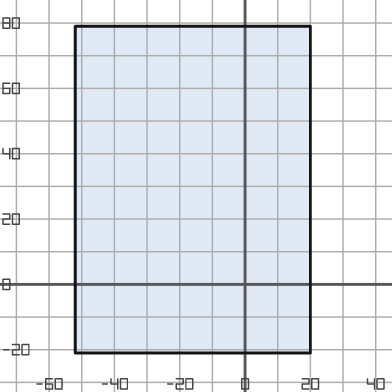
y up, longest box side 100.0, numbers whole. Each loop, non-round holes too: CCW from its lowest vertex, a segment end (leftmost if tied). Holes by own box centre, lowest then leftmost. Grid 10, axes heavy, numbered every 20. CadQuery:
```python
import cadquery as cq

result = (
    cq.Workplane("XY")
    .moveTo(-52.0, -21.0)
    .lineTo(20.0, -21.0)
    .lineTo(20.0, 79.0)
    .lineTo(-52.0, 79.0)
    .close()
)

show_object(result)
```